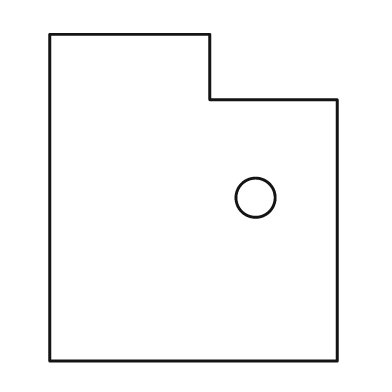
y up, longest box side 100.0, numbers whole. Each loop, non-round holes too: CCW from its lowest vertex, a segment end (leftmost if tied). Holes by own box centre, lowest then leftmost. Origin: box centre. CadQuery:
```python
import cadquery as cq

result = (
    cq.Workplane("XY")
    .moveTo(-44.0, -50.0)
    .lineTo(44.0, -50.0)
    .lineTo(44.0, 30.0)
    .lineTo(5.0, 30.0)
    .lineTo(5.0, 50.0)
    .lineTo(-44.0, 50.0)
    .close()
    .moveTo(19.0, 0.0)
    .circle(6.0)
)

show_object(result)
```